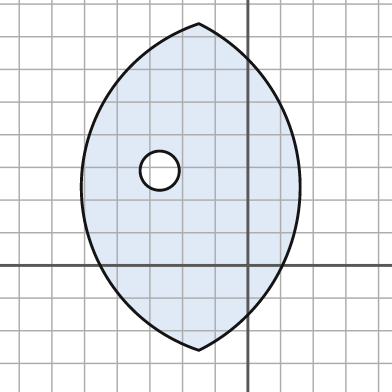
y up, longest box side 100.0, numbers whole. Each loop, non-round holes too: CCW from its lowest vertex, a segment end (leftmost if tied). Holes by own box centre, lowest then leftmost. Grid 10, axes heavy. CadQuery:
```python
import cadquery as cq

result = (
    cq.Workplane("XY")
    .moveTo(-15.0, -26.0)
    .threePointArc((16.0, 24.0), (-15.0, 74.0))
    .threePointArc((-51.0, 24.0), (-15.0, -26.0))
    .close()
    .moveTo(-27.0, 29.0)
    .circle(6.0)
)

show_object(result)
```